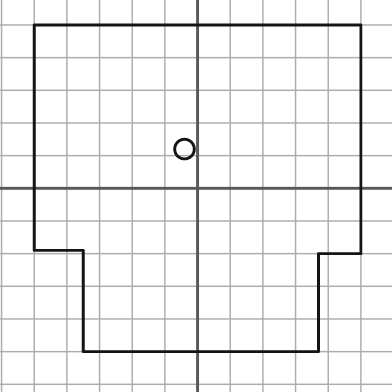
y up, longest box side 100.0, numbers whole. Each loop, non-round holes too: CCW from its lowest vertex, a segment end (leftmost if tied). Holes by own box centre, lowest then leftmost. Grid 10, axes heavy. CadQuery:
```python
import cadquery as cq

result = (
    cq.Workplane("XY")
    .moveTo(-35.0, -50.0)
    .lineTo(37.0, -50.0)
    .lineTo(37.0, -20.0)
    .lineTo(50.0, -20.0)
    .lineTo(50.0, 50.0)
    .lineTo(-50.0, 50.0)
    .lineTo(-50.0, -19.0)
    .lineTo(-35.0, -19.0)
    .close()
    .moveTo(-4.0, 12.0)
    .circle(3.0)
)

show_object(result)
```